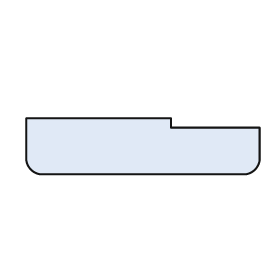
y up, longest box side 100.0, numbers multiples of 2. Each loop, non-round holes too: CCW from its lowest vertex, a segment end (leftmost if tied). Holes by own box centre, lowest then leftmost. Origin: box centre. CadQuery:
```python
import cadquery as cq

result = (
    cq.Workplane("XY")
    .moveTo(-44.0, -12.0)
    .lineTo(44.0, -12.0)
    .threePointArc((48.0, -10.0), (50.0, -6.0))
    .lineTo(50.0, 8.0)
    .lineTo(12.0, 8.0)
    .lineTo(12.0, 12.0)
    .lineTo(-50.0, 12.0)
    .lineTo(-50.0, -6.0)
    .threePointArc((-48.0, -10.0), (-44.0, -12.0))
    .close()
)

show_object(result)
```